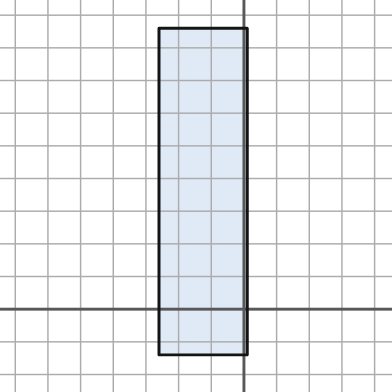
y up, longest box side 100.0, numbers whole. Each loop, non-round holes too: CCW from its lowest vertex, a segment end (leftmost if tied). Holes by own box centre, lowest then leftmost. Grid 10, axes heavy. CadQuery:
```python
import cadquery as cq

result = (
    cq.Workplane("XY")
    .moveTo(-26.0, -14.0)
    .lineTo(1.0, -14.0)
    .lineTo(1.0, 86.0)
    .lineTo(-26.0, 86.0)
    .close()
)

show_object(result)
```